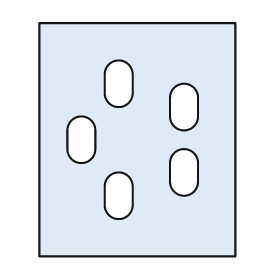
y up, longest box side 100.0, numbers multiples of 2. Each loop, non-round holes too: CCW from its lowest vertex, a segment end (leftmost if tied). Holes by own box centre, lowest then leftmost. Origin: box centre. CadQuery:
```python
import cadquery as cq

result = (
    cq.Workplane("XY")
    .moveTo(-42.0, -50.0)
    .lineTo(42.0, -50.0)
    .lineTo(42.0, 50.0)
    .lineTo(-42.0, 50.0)
    .close()
    .moveTo(-14.0, -28.0)
    .threePointArc((-8.0, -34.0), (-2.0, -28.0))
    .lineTo(-2.0, -20.0)
    .threePointArc((-8.0, -14.0), (-14.0, -20.0))
    .close()
    .moveTo(14.0, -18.0)
    .threePointArc((20.0, -24.0), (26.0, -18.0))
    .lineTo(26.0, -10.0)
    .threePointArc((20.0, -4.0), (14.0, -10.0))
    .close()
    .moveTo(-30.0, -4.0)
    .threePointArc((-24.0, -10.0), (-18.0, -4.0))
    .lineTo(-18.0, 4.0)
    .threePointArc((-24.0, 10.0), (-30.0, 4.0))
    .close()
    .moveTo(14.0, 10.0)
    .threePointArc((20.0, 4.0), (26.0, 10.0))
    .lineTo(26.0, 18.0)
    .threePointArc((20.0, 24.0), (14.0, 18.0))
    .close()
    .moveTo(-14.0, 20.0)
    .threePointArc((-8.0, 14.0), (-2.0, 20.0))
    .lineTo(-2.0, 28.0)
    .threePointArc((-8.0, 34.0), (-14.0, 28.0))
    .close()
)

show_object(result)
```